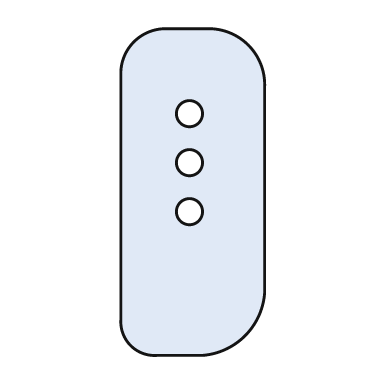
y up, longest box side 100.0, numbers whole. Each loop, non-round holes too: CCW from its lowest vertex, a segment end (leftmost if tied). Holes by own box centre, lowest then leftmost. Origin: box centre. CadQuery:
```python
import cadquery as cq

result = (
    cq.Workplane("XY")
    .moveTo(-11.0, -50.0)
    .lineTo(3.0, -50.0)
    .threePointArc((16.0, -44.0), (22.0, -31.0))
    .lineTo(22.0, 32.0)
    .threePointArc((17.0, 45.0), (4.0, 50.0))
    .lineTo(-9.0, 50.0)
    .threePointArc((-18.0, 46.0), (-22.0, 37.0))
    .lineTo(-22.0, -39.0)
    .threePointArc((-19.0, -47.0), (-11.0, -50.0))
    .close()
    .moveTo(-1.0, -6.0)
    .circle(4.0)
    .moveTo(-1.0, 9.0)
    .circle(4.0)
    .moveTo(-1.0, 24.0)
    .circle(4.0)
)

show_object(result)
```